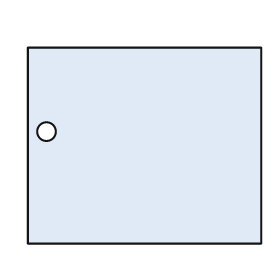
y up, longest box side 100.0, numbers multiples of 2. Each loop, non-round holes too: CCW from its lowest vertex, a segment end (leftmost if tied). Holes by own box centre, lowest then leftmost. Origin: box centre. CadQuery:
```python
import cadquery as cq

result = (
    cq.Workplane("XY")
    .moveTo(-50.0, -42.0)
    .lineTo(50.0, -42.0)
    .lineTo(50.0, 42.0)
    .lineTo(-50.0, 42.0)
    .close()
    .moveTo(-42.0, 6.0)
    .circle(4.0)
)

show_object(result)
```